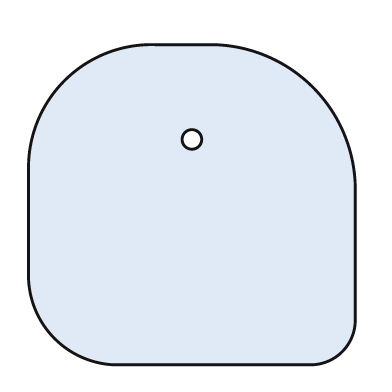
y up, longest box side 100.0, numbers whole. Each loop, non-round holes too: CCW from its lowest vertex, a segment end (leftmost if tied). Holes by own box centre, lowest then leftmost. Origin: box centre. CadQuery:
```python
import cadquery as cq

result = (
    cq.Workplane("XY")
    .moveTo(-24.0, -49.0)
    .lineTo(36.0, -49.0)
    .threePointArc((46.0, -45.0), (50.0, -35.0))
    .lineTo(50.0, 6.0)
    .threePointArc((37.0, 36.0), (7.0, 49.0))
    .lineTo(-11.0, 49.0)
    .threePointArc((-39.0, 38.0), (-50.0, 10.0))
    .lineTo(-50.0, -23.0)
    .threePointArc((-42.0, -41.0), (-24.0, -49.0))
    .close()
    .moveTo(0.0, 20.0)
    .circle(3.0)
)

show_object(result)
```